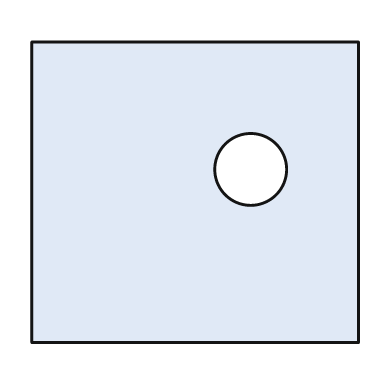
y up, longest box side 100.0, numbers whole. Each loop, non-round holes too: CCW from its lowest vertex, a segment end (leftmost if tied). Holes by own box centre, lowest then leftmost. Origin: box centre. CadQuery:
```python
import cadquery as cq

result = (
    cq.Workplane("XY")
    .moveTo(-50.0, -46.0)
    .lineTo(50.0, -46.0)
    .lineTo(50.0, 46.0)
    .lineTo(-50.0, 46.0)
    .close()
    .moveTo(17.0, 7.0)
    .circle(11.0)
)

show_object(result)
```